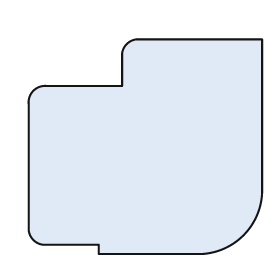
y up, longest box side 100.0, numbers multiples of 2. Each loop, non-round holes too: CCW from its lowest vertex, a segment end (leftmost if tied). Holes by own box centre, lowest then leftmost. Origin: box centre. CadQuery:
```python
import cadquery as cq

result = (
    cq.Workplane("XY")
    .moveTo(-20.0, -46.0)
    .lineTo(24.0, -46.0)
    .threePointArc((42.0, -38.0), (50.0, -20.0))
    .lineTo(50.0, 46.0)
    .lineTo(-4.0, 46.0)
    .threePointArc((-8.0, 44.0), (-10.0, 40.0))
    .lineTo(-10.0, 26.0)
    .lineTo(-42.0, 26.0)
    .threePointArc((-48.0, 24.0), (-50.0, 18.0))
    .lineTo(-50.0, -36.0)
    .threePointArc((-48.0, -40.0), (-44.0, -42.0))
    .lineTo(-20.0, -42.0)
    .close()
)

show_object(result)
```